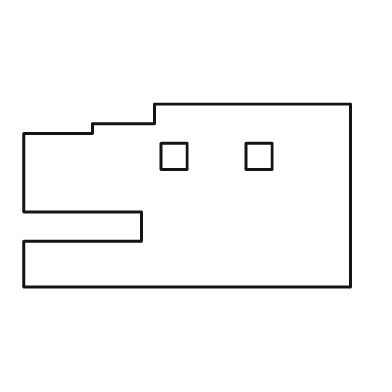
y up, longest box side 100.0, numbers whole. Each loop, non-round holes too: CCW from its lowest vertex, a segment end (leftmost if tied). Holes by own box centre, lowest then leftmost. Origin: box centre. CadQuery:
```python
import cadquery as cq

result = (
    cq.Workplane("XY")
    .moveTo(-50.0, -28.0)
    .lineTo(50.0, -28.0)
    .lineTo(50.0, 28.0)
    .lineTo(-10.0, 28.0)
    .lineTo(-10.0, 22.0)
    .lineTo(-29.0, 22.0)
    .lineTo(-29.0, 19.0)
    .lineTo(-50.0, 19.0)
    .lineTo(-50.0, -5.0)
    .lineTo(-14.0, -5.0)
    .lineTo(-14.0, -14.0)
    .lineTo(-50.0, -14.0)
    .close()
    .moveTo(-8.0, 8.0)
    .lineTo(0.0, 8.0)
    .lineTo(0.0, 16.0)
    .lineTo(-8.0, 16.0)
    .close()
    .moveTo(18.0, 8.0)
    .lineTo(26.0, 8.0)
    .lineTo(26.0, 16.0)
    .lineTo(18.0, 16.0)
    .close()
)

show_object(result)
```